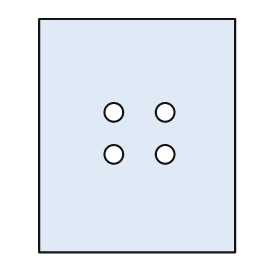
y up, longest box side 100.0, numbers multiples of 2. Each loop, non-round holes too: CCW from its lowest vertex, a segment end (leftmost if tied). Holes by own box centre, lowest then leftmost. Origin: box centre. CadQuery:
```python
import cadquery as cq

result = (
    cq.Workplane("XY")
    .moveTo(-42.0, -50.0)
    .lineTo(42.0, -50.0)
    .lineTo(42.0, 50.0)
    .lineTo(-42.0, 50.0)
    .close()
    .moveTo(-10.0, -8.0)
    .circle(4.0)
    .moveTo(12.0, -8.0)
    .circle(4.0)
    .moveTo(-10.0, 10.0)
    .circle(4.0)
    .moveTo(12.0, 10.0)
    .circle(4.0)
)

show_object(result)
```